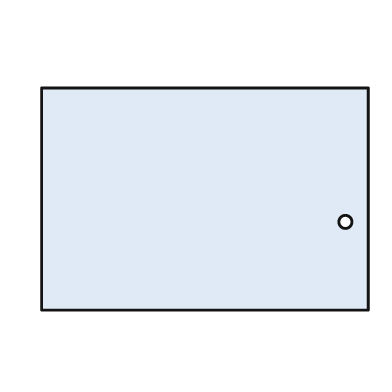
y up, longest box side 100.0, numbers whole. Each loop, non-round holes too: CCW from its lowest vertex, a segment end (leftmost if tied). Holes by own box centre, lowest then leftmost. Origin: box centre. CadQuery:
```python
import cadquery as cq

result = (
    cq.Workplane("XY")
    .moveTo(-50.0, -34.0)
    .lineTo(50.0, -34.0)
    .lineTo(50.0, 34.0)
    .lineTo(-50.0, 34.0)
    .close()
    .moveTo(43.0, -7.0)
    .circle(2.0)
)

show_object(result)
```